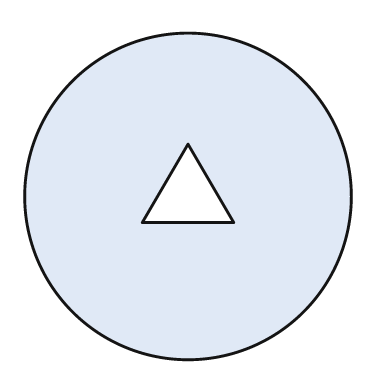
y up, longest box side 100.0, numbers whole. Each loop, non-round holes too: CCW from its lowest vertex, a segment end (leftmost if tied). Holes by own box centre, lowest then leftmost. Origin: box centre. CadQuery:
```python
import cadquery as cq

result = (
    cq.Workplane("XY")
    .moveTo(0.0, 0.0)
    .circle(50.0)
    .moveTo(-14.0, -8.0)
    .lineTo(14.0, -8.0)
    .lineTo(0.0, 16.0)
    .close()
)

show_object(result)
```